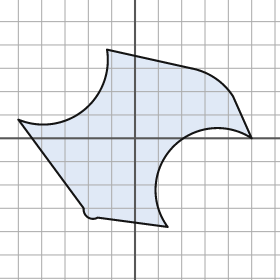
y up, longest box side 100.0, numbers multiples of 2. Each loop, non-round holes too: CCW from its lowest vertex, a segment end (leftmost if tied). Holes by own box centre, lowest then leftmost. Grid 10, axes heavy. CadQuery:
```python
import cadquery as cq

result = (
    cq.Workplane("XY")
    .moveTo(14.0, -38.0)
    .threePointArc((16.0, -4.0), (50.0, 0.0))
    .lineTo(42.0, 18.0)
    .threePointArc((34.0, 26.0), (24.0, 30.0))
    .lineTo(-12.0, 38.0)
    .threePointArc((-22.0, 12.0), (-50.0, 8.0))
    .lineTo(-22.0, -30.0)
    .threePointArc((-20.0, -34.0), (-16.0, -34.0))
    .close()
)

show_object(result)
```